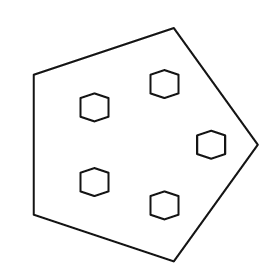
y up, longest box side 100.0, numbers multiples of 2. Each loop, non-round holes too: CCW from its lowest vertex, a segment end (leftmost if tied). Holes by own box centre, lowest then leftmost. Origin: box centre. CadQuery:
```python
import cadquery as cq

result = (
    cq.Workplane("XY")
    .moveTo(12.0, -50.0)
    .lineTo(48.0, 0.0)
    .lineTo(12.0, 50.0)
    .lineTo(-48.0, 30.0)
    .lineTo(-48.0, -30.0)
    .close()
    .moveTo(8.0, -32.0)
    .lineTo(14.0, -30.0)
    .lineTo(14.0, -22.0)
    .lineTo(8.0, -20.0)
    .lineTo(2.0, -22.0)
    .lineTo(2.0, -30.0)
    .close()
    .moveTo(-22.0, -22.0)
    .lineTo(-16.0, -20.0)
    .lineTo(-16.0, -12.0)
    .lineTo(-22.0, -10.0)
    .lineTo(-28.0, -12.0)
    .lineTo(-28.0, -20.0)
    .close()
    .moveTo(28.0, -6.0)
    .lineTo(34.0, -4.0)
    .lineTo(34.0, 4.0)
    .lineTo(28.0, 6.0)
    .lineTo(22.0, 4.0)
    .lineTo(22.0, -4.0)
    .close()
    .moveTo(-22.0, 10.0)
    .lineTo(-16.0, 12.0)
    .lineTo(-16.0, 20.0)
    .lineTo(-22.0, 22.0)
    .lineTo(-28.0, 20.0)
    .lineTo(-28.0, 12.0)
    .close()
    .moveTo(8.0, 20.0)
    .lineTo(14.0, 22.0)
    .lineTo(14.0, 30.0)
    .lineTo(8.0, 32.0)
    .lineTo(2.0, 30.0)
    .lineTo(2.0, 22.0)
    .close()
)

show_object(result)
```